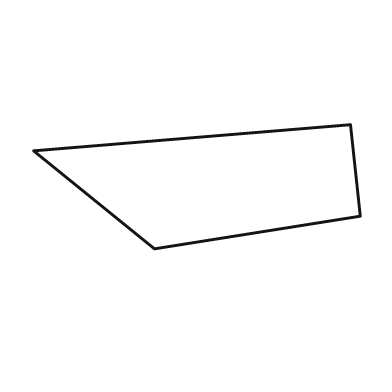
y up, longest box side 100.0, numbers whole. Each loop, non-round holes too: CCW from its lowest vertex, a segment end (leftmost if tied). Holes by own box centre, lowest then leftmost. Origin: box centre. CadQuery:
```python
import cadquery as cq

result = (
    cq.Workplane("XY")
    .moveTo(-13.0, -19.0)
    .lineTo(50.0, -9.0)
    .lineTo(47.0, 19.0)
    .lineTo(-50.0, 11.0)
    .close()
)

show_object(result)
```